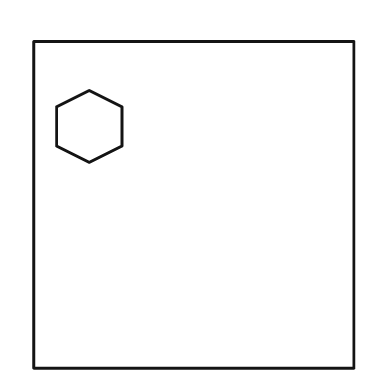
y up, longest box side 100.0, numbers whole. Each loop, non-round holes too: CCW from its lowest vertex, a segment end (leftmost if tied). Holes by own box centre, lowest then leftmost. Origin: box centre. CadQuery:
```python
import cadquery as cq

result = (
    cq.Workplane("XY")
    .moveTo(-49.0, -50.0)
    .lineTo(49.0, -50.0)
    .lineTo(49.0, 50.0)
    .lineTo(-49.0, 50.0)
    .close()
    .moveTo(-32.0, 13.0)
    .lineTo(-22.0, 18.0)
    .lineTo(-22.0, 30.0)
    .lineTo(-32.0, 35.0)
    .lineTo(-42.0, 30.0)
    .lineTo(-42.0, 18.0)
    .close()
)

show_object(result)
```